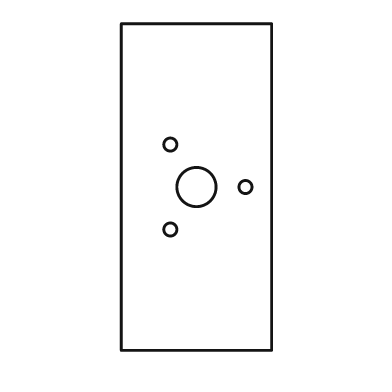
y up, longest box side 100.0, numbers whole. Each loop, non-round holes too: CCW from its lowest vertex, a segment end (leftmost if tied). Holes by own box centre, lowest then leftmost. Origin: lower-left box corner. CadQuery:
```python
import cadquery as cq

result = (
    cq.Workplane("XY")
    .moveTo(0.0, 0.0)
    .lineTo(46.0, 0.0)
    .lineTo(46.0, 100.0)
    .lineTo(0.0, 100.0)
    .close()
    .moveTo(15.0, 37.0)
    .circle(2.0)
    .moveTo(23.0, 50.0)
    .circle(6.0)
    .moveTo(38.0, 50.0)
    .circle(2.0)
    .moveTo(15.0, 63.0)
    .circle(2.0)
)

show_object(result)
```